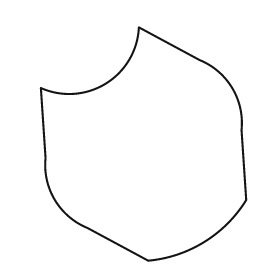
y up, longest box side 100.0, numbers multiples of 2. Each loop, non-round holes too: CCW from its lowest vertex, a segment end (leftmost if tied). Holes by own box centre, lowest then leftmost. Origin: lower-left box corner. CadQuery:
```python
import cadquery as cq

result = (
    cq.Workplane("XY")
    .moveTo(46.0, 0.0)
    .threePointArc((70.0, 8.0), (88.0, 26.0))
    .lineTo(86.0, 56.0)
    .threePointArc((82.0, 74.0), (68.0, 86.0))
    .lineTo(42.0, 100.0)
    .threePointArc((28.0, 76.0), (0.0, 74.0))
    .lineTo(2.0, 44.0)
    .threePointArc((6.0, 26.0), (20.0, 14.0))
    .close()
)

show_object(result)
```